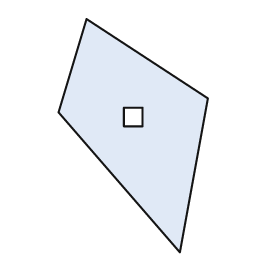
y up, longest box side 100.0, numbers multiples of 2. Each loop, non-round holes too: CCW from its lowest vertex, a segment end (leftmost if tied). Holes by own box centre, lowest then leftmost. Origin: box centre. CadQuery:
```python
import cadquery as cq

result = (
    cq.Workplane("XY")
    .moveTo(20.0, -50.0)
    .lineTo(32.0, 16.0)
    .lineTo(-20.0, 50.0)
    .lineTo(-32.0, 10.0)
    .close()
    .moveTo(-4.0, 4.0)
    .lineTo(4.0, 4.0)
    .lineTo(4.0, 12.0)
    .lineTo(-4.0, 12.0)
    .close()
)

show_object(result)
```